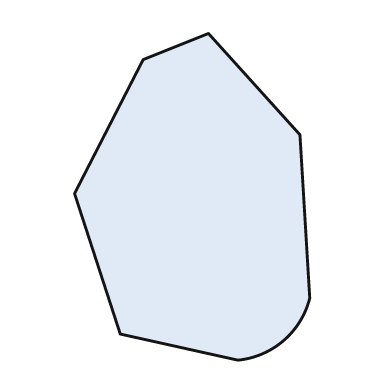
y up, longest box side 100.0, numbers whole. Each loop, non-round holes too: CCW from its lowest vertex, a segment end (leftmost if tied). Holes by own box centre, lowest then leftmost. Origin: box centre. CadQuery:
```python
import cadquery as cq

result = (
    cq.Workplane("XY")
    .moveTo(14.0, -50.0)
    .threePointArc((28.0, -44.0), (36.0, -31.0))
    .lineTo(33.0, 19.0)
    .lineTo(5.0, 50.0)
    .lineTo(-15.0, 42.0)
    .lineTo(-36.0, 1.0)
    .lineTo(-22.0, -42.0)
    .close()
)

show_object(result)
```